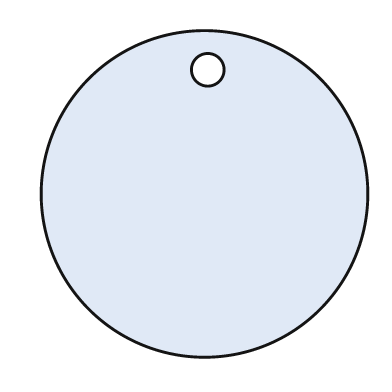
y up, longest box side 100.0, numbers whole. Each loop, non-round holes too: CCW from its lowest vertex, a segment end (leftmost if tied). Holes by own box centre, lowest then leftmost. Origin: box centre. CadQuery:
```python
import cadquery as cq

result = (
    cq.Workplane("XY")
    .moveTo(0.0, 0.0)
    .circle(50.0)
    .moveTo(1.0, 38.0)
    .circle(5.0)
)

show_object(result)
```